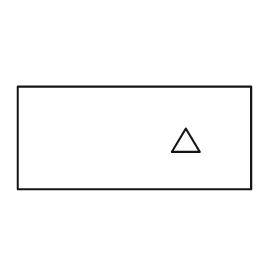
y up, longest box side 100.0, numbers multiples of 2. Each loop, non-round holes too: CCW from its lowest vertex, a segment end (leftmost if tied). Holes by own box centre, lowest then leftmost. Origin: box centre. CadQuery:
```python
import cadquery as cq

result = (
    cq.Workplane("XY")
    .moveTo(-50.0, -22.0)
    .lineTo(50.0, -22.0)
    .lineTo(50.0, 22.0)
    .lineTo(-50.0, 22.0)
    .close()
    .moveTo(16.0, -6.0)
    .lineTo(28.0, -6.0)
    .lineTo(22.0, 4.0)
    .close()
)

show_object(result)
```